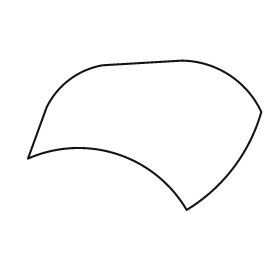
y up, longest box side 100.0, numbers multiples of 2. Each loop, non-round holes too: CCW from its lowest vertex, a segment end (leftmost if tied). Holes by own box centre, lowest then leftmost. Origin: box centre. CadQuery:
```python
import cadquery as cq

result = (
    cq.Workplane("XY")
    .moveTo(18.0, -32.0)
    .threePointArc((38.0, -14.0), (50.0, 10.0))
    .threePointArc((36.0, 26.0), (16.0, 32.0))
    .lineTo(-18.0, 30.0)
    .threePointArc((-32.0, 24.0), (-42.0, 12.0))
    .lineTo(-50.0, -10.0)
    .threePointArc((-12.0, -8.0), (18.0, -32.0))
    .close()
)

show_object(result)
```